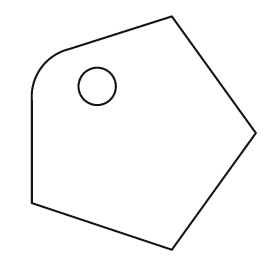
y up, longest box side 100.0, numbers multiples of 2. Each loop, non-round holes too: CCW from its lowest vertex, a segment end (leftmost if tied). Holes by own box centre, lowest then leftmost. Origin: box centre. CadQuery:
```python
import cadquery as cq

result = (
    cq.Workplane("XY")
    .moveTo(12.0, -50.0)
    .lineTo(48.0, 0.0)
    .lineTo(12.0, 50.0)
    .lineTo(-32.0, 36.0)
    .threePointArc((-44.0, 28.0), (-48.0, 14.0))
    .lineTo(-48.0, -30.0)
    .close()
    .moveTo(-20.0, 20.0)
    .circle(8.0)
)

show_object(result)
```